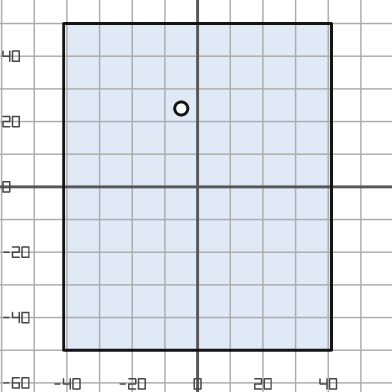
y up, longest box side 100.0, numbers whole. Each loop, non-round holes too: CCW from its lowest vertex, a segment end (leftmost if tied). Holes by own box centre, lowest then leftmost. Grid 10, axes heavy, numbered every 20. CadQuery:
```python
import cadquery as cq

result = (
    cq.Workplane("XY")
    .moveTo(-41.0, -50.0)
    .lineTo(41.0, -50.0)
    .lineTo(41.0, 50.0)
    .lineTo(-41.0, 50.0)
    .close()
    .moveTo(-5.0, 24.0)
    .circle(2.0)
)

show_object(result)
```